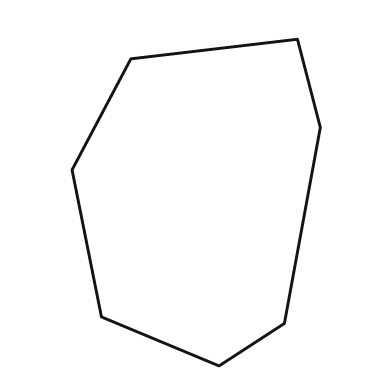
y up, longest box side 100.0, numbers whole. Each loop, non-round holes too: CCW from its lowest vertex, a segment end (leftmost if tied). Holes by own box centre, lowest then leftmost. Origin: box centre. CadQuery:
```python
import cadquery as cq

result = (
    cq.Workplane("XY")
    .moveTo(7.0, -50.0)
    .lineTo(27.0, -37.0)
    .lineTo(38.0, 23.0)
    .lineTo(31.0, 50.0)
    .lineTo(-20.0, 44.0)
    .lineTo(-38.0, 10.0)
    .lineTo(-29.0, -35.0)
    .close()
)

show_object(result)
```